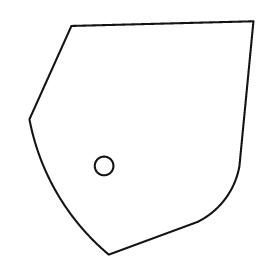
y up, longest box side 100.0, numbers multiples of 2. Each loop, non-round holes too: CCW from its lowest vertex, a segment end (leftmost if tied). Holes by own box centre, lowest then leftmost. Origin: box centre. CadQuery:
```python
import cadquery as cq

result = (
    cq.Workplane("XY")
    .moveTo(-14.0, -50.0)
    .lineTo(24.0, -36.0)
    .threePointArc((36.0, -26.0), (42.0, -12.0))
    .lineTo(48.0, 50.0)
    .lineTo(-30.0, 48.0)
    .lineTo(-48.0, 8.0)
    .threePointArc((-36.0, -24.0), (-14.0, -50.0))
    .close()
    .moveTo(-16.0, -12.0)
    .circle(4.0)
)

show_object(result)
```